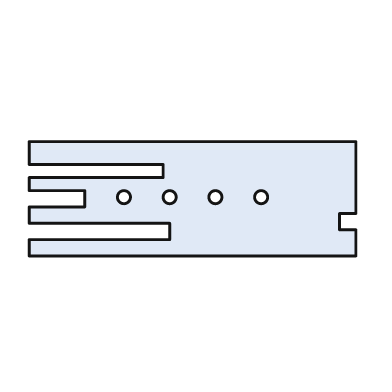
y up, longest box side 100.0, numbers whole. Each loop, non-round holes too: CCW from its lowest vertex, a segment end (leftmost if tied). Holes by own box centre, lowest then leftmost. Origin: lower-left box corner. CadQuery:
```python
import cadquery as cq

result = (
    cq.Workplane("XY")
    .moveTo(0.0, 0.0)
    .lineTo(100.0, 0.0)
    .lineTo(100.0, 8.0)
    .lineTo(95.0, 8.0)
    .lineTo(95.0, 13.0)
    .lineTo(100.0, 13.0)
    .lineTo(100.0, 35.0)
    .lineTo(0.0, 35.0)
    .lineTo(0.0, 28.0)
    .lineTo(41.0, 28.0)
    .lineTo(41.0, 24.0)
    .lineTo(0.0, 24.0)
    .lineTo(0.0, 20.0)
    .lineTo(17.0, 20.0)
    .lineTo(17.0, 15.0)
    .lineTo(0.0, 15.0)
    .lineTo(0.0, 10.0)
    .lineTo(43.0, 10.0)
    .lineTo(43.0, 5.0)
    .lineTo(0.0, 5.0)
    .close()
    .moveTo(29.0, 18.0)
    .circle(2.0)
    .moveTo(43.0, 18.0)
    .circle(2.0)
    .moveTo(57.0, 18.0)
    .circle(2.0)
    .moveTo(71.0, 18.0)
    .circle(2.0)
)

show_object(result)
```